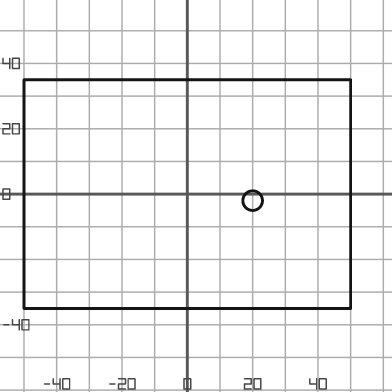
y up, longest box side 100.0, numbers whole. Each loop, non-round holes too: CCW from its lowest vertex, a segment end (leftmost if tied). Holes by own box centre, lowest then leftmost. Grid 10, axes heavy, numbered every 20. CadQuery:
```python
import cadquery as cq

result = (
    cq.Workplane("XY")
    .moveTo(-50.0, -35.0)
    .lineTo(50.0, -35.0)
    .lineTo(50.0, 35.0)
    .lineTo(-50.0, 35.0)
    .close()
    .moveTo(20.0, -2.0)
    .circle(3.0)
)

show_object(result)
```